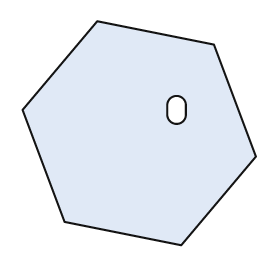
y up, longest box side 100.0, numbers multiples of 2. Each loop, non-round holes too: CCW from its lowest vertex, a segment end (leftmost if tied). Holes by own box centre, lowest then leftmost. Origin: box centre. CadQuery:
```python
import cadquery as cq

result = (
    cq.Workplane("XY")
    .moveTo(18.0, -48.0)
    .lineTo(50.0, -10.0)
    .lineTo(32.0, 38.0)
    .lineTo(-18.0, 48.0)
    .lineTo(-50.0, 10.0)
    .lineTo(-32.0, -38.0)
    .close()
    .moveTo(12.0, 8.0)
    .threePointArc((16.0, 4.0), (20.0, 8.0))
    .lineTo(20.0, 12.0)
    .threePointArc((16.0, 16.0), (12.0, 12.0))
    .close()
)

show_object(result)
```